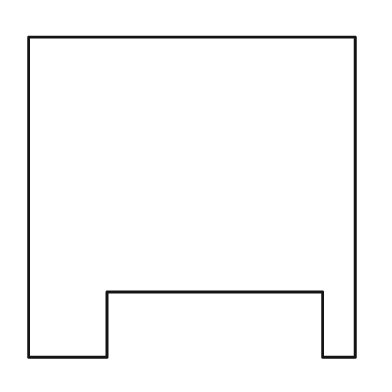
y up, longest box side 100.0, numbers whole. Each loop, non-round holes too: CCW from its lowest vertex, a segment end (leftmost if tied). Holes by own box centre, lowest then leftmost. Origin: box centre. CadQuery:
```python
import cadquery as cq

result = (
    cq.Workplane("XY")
    .moveTo(-50.0, -49.0)
    .lineTo(-26.0, -49.0)
    .lineTo(-26.0, -29.0)
    .lineTo(40.0, -29.0)
    .lineTo(40.0, -49.0)
    .lineTo(50.0, -49.0)
    .lineTo(50.0, 49.0)
    .lineTo(-50.0, 49.0)
    .close()
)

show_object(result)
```